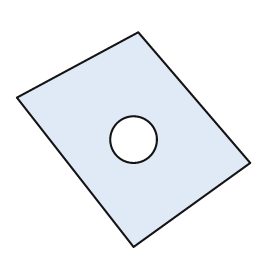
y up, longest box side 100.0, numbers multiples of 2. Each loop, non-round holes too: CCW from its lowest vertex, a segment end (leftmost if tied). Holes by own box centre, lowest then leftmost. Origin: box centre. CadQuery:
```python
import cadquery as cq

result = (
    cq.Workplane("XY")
    .moveTo(0.0, -46.0)
    .lineTo(50.0, -10.0)
    .lineTo(2.0, 46.0)
    .lineTo(-50.0, 18.0)
    .close()
    .moveTo(0.0, 0.0)
    .circle(10.0)
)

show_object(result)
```